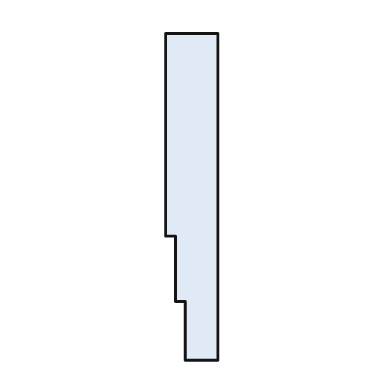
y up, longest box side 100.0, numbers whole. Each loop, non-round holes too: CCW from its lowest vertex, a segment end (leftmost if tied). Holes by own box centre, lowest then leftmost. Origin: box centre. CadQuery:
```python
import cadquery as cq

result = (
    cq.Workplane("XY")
    .moveTo(-2.0, -50.0)
    .lineTo(8.0, -50.0)
    .lineTo(8.0, 50.0)
    .lineTo(-8.0, 50.0)
    .lineTo(-8.0, -12.0)
    .lineTo(-5.0, -12.0)
    .lineTo(-5.0, -32.0)
    .lineTo(-2.0, -32.0)
    .close()
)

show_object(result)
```